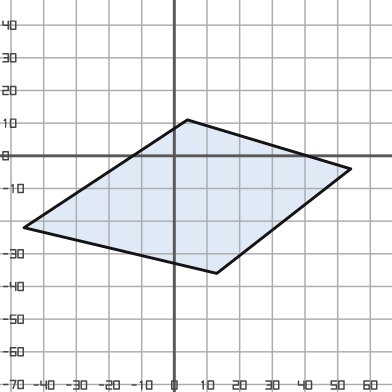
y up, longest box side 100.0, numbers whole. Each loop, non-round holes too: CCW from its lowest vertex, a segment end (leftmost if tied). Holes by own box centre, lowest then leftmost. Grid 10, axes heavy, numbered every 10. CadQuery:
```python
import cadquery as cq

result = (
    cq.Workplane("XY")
    .moveTo(13.0, -36.0)
    .lineTo(54.0, -4.0)
    .lineTo(4.0, 11.0)
    .lineTo(-46.0, -22.0)
    .close()
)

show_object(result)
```